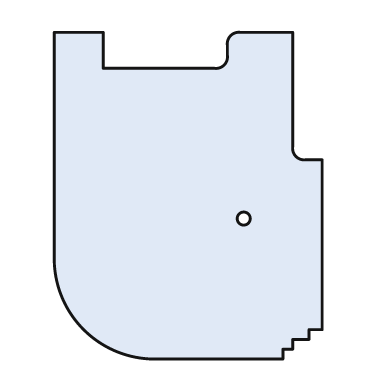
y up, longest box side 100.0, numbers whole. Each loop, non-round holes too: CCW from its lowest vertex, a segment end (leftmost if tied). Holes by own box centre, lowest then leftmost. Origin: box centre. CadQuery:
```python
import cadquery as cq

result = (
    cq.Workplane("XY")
    .moveTo(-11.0, -50.0)
    .lineTo(29.0, -50.0)
    .lineTo(29.0, -47.0)
    .lineTo(32.0, -47.0)
    .lineTo(32.0, -44.0)
    .lineTo(37.0, -44.0)
    .lineTo(37.0, -41.0)
    .lineTo(41.0, -41.0)
    .lineTo(41.0, 11.0)
    .lineTo(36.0, 11.0)
    .threePointArc((33.0, 12.0), (32.0, 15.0))
    .lineTo(32.0, 50.0)
    .lineTo(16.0, 50.0)
    .threePointArc((13.0, 49.0), (12.0, 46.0))
    .lineTo(12.0, 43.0)
    .threePointArc((11.0, 40.0), (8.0, 39.0))
    .lineTo(-26.0, 39.0)
    .lineTo(-26.0, 50.0)
    .lineTo(-41.0, 50.0)
    .lineTo(-41.0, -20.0)
    .threePointArc((-32.0, -41.0), (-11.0, -50.0))
    .close()
    .moveTo(17.0, -7.0)
    .circle(2.0)
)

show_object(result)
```